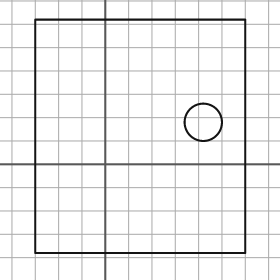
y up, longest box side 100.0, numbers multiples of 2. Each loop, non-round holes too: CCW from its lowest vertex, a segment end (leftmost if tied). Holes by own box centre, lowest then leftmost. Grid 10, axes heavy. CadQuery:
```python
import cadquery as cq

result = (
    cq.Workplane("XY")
    .moveTo(-30.0, -38.0)
    .lineTo(60.0, -38.0)
    .lineTo(60.0, 62.0)
    .lineTo(-30.0, 62.0)
    .close()
    .moveTo(42.0, 18.0)
    .circle(8.0)
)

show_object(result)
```